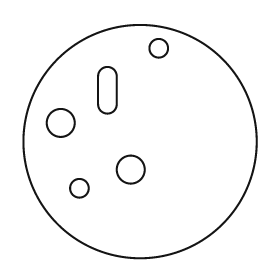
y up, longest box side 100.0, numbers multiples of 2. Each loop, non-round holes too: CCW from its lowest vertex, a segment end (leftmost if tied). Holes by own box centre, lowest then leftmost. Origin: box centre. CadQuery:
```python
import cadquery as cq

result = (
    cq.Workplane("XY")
    .moveTo(0.0, 0.0)
    .circle(50.0)
    .moveTo(-26.0, -20.0)
    .circle(4.0)
    .moveTo(-4.0, -12.0)
    .circle(6.0)
    .moveTo(-34.0, 8.0)
    .circle(6.0)
    .moveTo(-18.0, 16.0)
    .threePointArc((-14.0, 12.0), (-10.0, 16.0))
    .lineTo(-10.0, 28.0)
    .threePointArc((-14.0, 32.0), (-18.0, 28.0))
    .close()
    .moveTo(8.0, 40.0)
    .circle(4.0)
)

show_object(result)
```